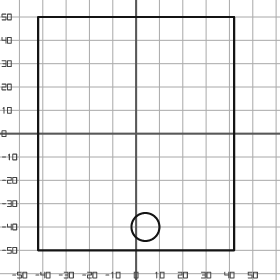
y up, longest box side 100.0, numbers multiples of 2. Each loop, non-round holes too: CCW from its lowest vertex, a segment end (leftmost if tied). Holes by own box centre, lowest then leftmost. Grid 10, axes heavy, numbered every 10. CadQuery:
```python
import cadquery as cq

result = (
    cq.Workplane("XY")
    .moveTo(-42.0, -50.0)
    .lineTo(42.0, -50.0)
    .lineTo(42.0, 50.0)
    .lineTo(-42.0, 50.0)
    .close()
    .moveTo(4.0, -40.0)
    .circle(6.0)
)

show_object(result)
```